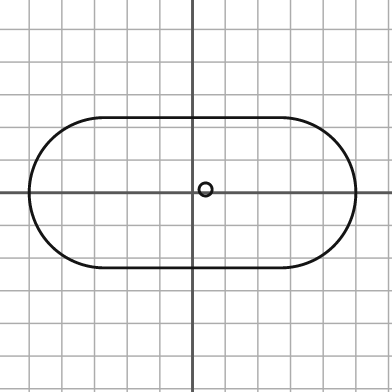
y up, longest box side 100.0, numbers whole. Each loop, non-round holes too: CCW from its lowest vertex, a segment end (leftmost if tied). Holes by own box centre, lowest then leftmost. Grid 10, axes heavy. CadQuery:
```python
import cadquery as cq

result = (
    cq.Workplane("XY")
    .moveTo(-27.0, -23.0)
    .lineTo(27.0, -23.0)
    .threePointArc((50.0, 0.0), (27.0, 23.0))
    .lineTo(-27.0, 23.0)
    .threePointArc((-50.0, 0.0), (-27.0, -23.0))
    .close()
    .moveTo(4.0, 1.0)
    .circle(2.0)
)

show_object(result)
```